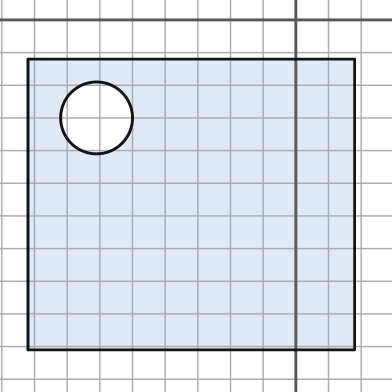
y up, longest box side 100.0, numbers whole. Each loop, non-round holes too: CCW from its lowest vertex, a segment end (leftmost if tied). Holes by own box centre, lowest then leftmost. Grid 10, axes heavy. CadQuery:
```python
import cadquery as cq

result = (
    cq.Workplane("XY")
    .moveTo(-82.0, -101.0)
    .lineTo(18.0, -101.0)
    .lineTo(18.0, -12.0)
    .lineTo(-82.0, -12.0)
    .close()
    .moveTo(-61.0, -30.0)
    .circle(11.0)
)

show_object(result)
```